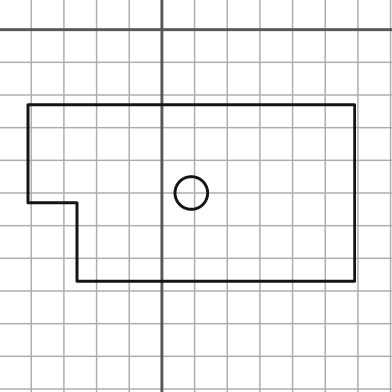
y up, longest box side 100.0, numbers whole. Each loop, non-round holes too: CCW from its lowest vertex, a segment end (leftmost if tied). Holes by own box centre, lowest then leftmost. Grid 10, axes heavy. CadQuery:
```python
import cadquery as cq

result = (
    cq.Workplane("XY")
    .moveTo(-26.0, -77.0)
    .lineTo(59.0, -77.0)
    .lineTo(59.0, -23.0)
    .lineTo(-41.0, -23.0)
    .lineTo(-41.0, -53.0)
    .lineTo(-26.0, -53.0)
    .close()
    .moveTo(9.0, -50.0)
    .circle(5.0)
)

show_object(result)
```